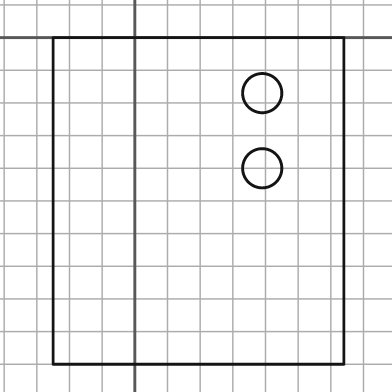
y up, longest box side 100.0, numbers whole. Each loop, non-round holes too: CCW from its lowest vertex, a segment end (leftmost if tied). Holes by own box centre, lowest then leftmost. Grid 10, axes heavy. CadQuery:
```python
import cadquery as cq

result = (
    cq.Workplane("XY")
    .moveTo(-25.0, -100.0)
    .lineTo(64.0, -100.0)
    .lineTo(64.0, 0.0)
    .lineTo(-25.0, 0.0)
    .close()
    .moveTo(39.0, -40.0)
    .circle(6.0)
    .moveTo(39.0, -17.0)
    .circle(6.0)
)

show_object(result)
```